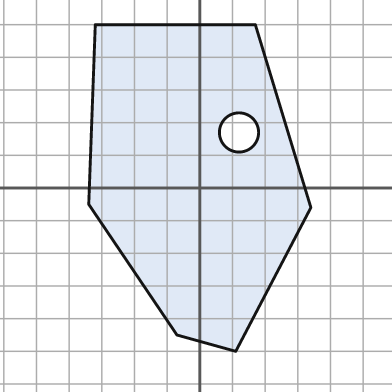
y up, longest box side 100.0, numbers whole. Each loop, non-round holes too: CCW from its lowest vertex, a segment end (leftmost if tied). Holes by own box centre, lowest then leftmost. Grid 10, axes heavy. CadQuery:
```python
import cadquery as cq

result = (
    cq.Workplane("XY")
    .moveTo(11.0, -50.0)
    .lineTo(34.0, -6.0)
    .lineTo(17.0, 50.0)
    .lineTo(-32.0, 50.0)
    .lineTo(-34.0, -5.0)
    .lineTo(-7.0, -45.0)
    .close()
    .moveTo(12.0, 17.0)
    .circle(6.0)
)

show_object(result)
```